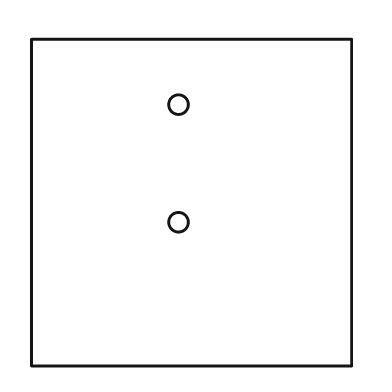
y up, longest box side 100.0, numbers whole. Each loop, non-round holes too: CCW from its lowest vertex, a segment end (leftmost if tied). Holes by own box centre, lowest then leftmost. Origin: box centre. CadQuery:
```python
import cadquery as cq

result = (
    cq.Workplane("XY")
    .moveTo(-49.0, -50.0)
    .lineTo(49.0, -50.0)
    .lineTo(49.0, 50.0)
    .lineTo(-49.0, 50.0)
    .close()
    .moveTo(-4.0, -6.0)
    .circle(3.0)
    .moveTo(-4.0, 30.0)
    .circle(3.0)
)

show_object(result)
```